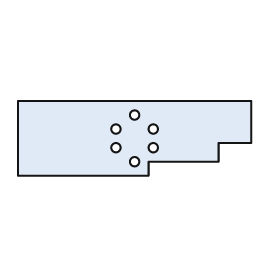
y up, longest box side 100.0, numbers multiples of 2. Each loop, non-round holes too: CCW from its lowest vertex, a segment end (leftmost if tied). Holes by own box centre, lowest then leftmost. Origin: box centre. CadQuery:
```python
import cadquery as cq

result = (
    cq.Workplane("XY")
    .moveTo(-50.0, -16.0)
    .lineTo(6.0, -16.0)
    .lineTo(6.0, -10.0)
    .lineTo(36.0, -10.0)
    .lineTo(36.0, -2.0)
    .lineTo(50.0, -2.0)
    .lineTo(50.0, 16.0)
    .lineTo(-50.0, 16.0)
    .close()
    .moveTo(0.0, -10.0)
    .circle(2.0)
    .moveTo(-8.0, -4.0)
    .circle(2.0)
    .moveTo(8.0, -4.0)
    .circle(2.0)
    .moveTo(-8.0, 4.0)
    .circle(2.0)
    .moveTo(8.0, 4.0)
    .circle(2.0)
    .moveTo(0.0, 10.0)
    .circle(2.0)
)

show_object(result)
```